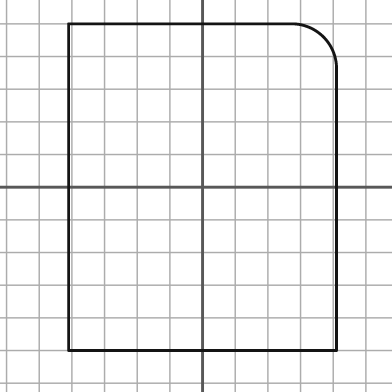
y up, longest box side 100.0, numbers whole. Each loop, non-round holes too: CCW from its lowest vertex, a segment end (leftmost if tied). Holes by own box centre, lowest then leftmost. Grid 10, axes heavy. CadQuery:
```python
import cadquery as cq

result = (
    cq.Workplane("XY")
    .moveTo(-41.0, -50.0)
    .lineTo(41.0, -50.0)
    .lineTo(41.0, 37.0)
    .threePointArc((37.0, 46.0), (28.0, 50.0))
    .lineTo(-41.0, 50.0)
    .close()
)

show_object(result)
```